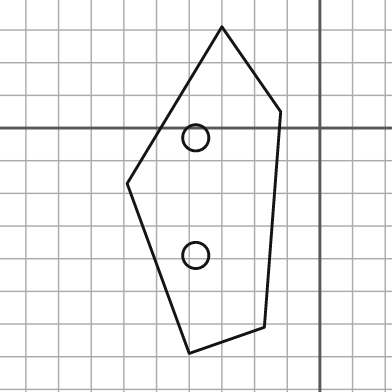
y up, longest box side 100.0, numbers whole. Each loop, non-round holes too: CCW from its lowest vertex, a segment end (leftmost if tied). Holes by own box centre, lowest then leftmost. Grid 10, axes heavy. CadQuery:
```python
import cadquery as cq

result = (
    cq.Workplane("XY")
    .moveTo(-40.0, -69.0)
    .lineTo(-17.0, -61.0)
    .lineTo(-12.0, 5.0)
    .lineTo(-30.0, 31.0)
    .lineTo(-59.0, -17.0)
    .close()
    .moveTo(-38.0, -39.0)
    .circle(4.0)
    .moveTo(-38.0, -3.0)
    .circle(4.0)
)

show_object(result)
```